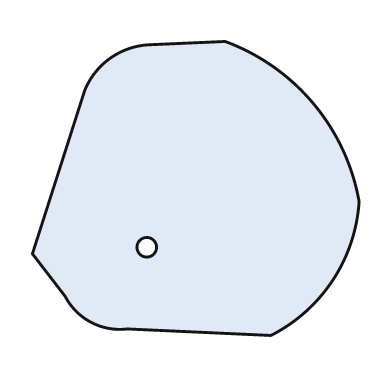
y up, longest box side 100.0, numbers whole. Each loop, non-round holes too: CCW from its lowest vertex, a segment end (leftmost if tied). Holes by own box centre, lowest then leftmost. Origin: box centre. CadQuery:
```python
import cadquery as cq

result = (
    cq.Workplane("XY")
    .moveTo(23.0, -45.0)
    .threePointArc((42.0, -28.0), (50.0, -4.0))
    .threePointArc((36.0, 26.0), (9.0, 45.0))
    .lineTo(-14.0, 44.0)
    .threePointArc((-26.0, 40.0), (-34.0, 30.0))
    .lineTo(-50.0, -20.0)
    .lineTo(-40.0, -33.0)
    .threePointArc((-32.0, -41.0), (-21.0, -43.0))
    .close()
    .moveTo(-15.0, -18.0)
    .circle(3.0)
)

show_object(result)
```